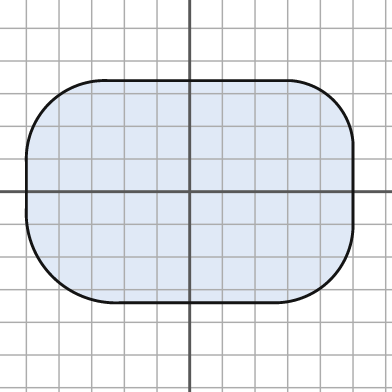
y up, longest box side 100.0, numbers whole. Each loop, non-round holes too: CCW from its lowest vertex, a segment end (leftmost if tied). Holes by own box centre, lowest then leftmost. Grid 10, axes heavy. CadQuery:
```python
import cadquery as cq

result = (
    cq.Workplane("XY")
    .moveTo(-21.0, -34.0)
    .lineTo(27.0, -34.0)
    .threePointArc((43.0, -27.0), (50.0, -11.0))
    .lineTo(50.0, 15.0)
    .threePointArc((44.0, 28.0), (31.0, 34.0))
    .lineTo(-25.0, 34.0)
    .threePointArc((-43.0, 27.0), (-50.0, 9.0))
    .lineTo(-50.0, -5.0)
    .threePointArc((-42.0, -26.0), (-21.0, -34.0))
    .close()
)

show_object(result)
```